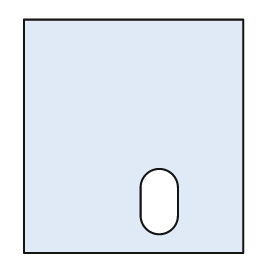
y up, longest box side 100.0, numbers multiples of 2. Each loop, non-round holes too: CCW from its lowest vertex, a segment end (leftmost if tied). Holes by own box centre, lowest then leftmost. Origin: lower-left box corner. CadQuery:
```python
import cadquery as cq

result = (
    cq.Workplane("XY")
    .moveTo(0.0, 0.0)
    .lineTo(94.0, 0.0)
    .lineTo(94.0, 100.0)
    .lineTo(0.0, 100.0)
    .close()
    .moveTo(50.0, 16.0)
    .threePointArc((58.0, 8.0), (66.0, 16.0))
    .lineTo(66.0, 28.0)
    .threePointArc((58.0, 36.0), (50.0, 28.0))
    .close()
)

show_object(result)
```